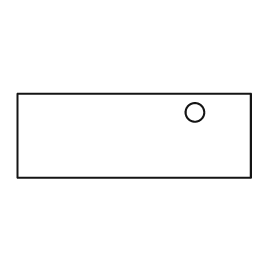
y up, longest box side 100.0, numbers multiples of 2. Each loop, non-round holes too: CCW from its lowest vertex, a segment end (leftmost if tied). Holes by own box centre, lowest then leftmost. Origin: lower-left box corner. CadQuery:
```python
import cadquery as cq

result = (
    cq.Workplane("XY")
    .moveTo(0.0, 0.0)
    .lineTo(100.0, 0.0)
    .lineTo(100.0, 36.0)
    .lineTo(0.0, 36.0)
    .close()
    .moveTo(76.0, 28.0)
    .circle(4.0)
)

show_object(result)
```